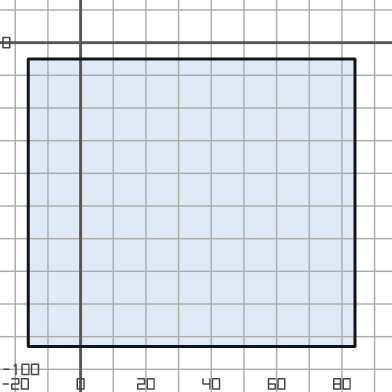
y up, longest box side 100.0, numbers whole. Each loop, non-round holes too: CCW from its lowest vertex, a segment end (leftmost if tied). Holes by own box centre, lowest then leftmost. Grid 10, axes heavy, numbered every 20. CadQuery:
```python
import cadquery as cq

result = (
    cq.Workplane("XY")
    .moveTo(-16.0, -93.0)
    .lineTo(84.0, -93.0)
    .lineTo(84.0, -5.0)
    .lineTo(-16.0, -5.0)
    .close()
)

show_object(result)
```